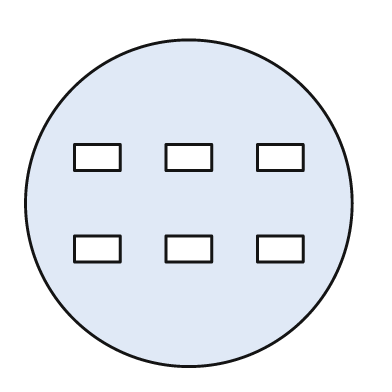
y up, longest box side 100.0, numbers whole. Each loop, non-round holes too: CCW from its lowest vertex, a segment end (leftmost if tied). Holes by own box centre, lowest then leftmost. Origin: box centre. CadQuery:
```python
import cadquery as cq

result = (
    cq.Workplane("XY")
    .moveTo(0.0, 0.0)
    .circle(50.0)
    .moveTo(-35.0, -18.0)
    .lineTo(-21.0, -18.0)
    .lineTo(-21.0, -10.0)
    .lineTo(-35.0, -10.0)
    .close()
    .moveTo(-7.0, -18.0)
    .lineTo(7.0, -18.0)
    .lineTo(7.0, -10.0)
    .lineTo(-7.0, -10.0)
    .close()
    .moveTo(21.0, -18.0)
    .lineTo(35.0, -18.0)
    .lineTo(35.0, -10.0)
    .lineTo(21.0, -10.0)
    .close()
    .moveTo(-35.0, 10.0)
    .lineTo(-21.0, 10.0)
    .lineTo(-21.0, 18.0)
    .lineTo(-35.0, 18.0)
    .close()
    .moveTo(-7.0, 10.0)
    .lineTo(7.0, 10.0)
    .lineTo(7.0, 18.0)
    .lineTo(-7.0, 18.0)
    .close()
    .moveTo(21.0, 10.0)
    .lineTo(35.0, 10.0)
    .lineTo(35.0, 18.0)
    .lineTo(21.0, 18.0)
    .close()
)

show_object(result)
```